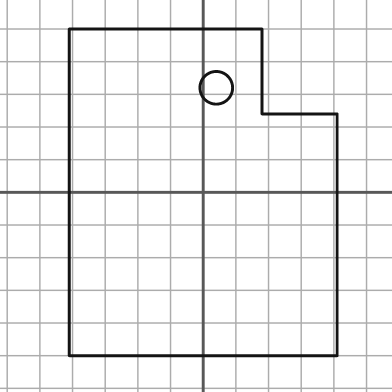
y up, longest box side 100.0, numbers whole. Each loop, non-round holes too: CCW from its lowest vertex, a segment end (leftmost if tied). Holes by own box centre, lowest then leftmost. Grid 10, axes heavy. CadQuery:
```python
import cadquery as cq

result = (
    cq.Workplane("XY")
    .moveTo(-41.0, -50.0)
    .lineTo(41.0, -50.0)
    .lineTo(41.0, 24.0)
    .lineTo(18.0, 24.0)
    .lineTo(18.0, 50.0)
    .lineTo(-41.0, 50.0)
    .close()
    .moveTo(4.0, 32.0)
    .circle(5.0)
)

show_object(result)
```